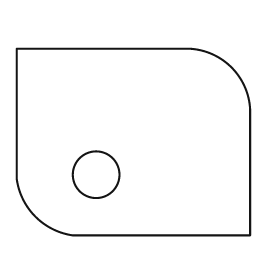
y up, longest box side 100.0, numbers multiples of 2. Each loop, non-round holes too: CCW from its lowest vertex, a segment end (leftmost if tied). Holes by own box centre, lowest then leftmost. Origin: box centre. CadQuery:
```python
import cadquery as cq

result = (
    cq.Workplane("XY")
    .moveTo(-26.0, -40.0)
    .lineTo(50.0, -40.0)
    .lineTo(50.0, 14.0)
    .threePointArc((42.0, 32.0), (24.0, 40.0))
    .lineTo(-50.0, 40.0)
    .lineTo(-50.0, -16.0)
    .threePointArc((-42.0, -32.0), (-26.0, -40.0))
    .close()
    .moveTo(-16.0, -14.0)
    .circle(10.0)
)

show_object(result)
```